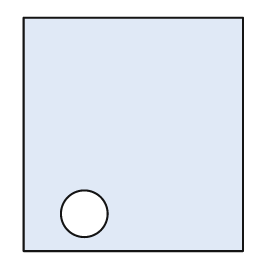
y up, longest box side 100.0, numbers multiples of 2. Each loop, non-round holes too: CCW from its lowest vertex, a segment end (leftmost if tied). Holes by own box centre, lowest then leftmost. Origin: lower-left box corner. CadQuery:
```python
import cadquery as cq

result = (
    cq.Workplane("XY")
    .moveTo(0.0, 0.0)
    .lineTo(94.0, 0.0)
    .lineTo(94.0, 100.0)
    .lineTo(0.0, 100.0)
    .close()
    .moveTo(26.0, 16.0)
    .circle(10.0)
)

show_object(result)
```